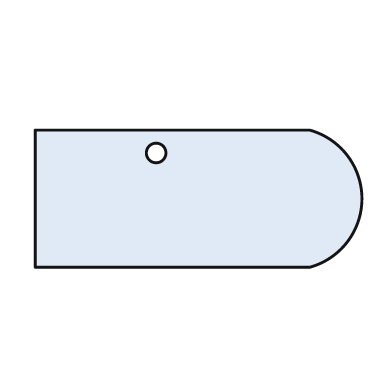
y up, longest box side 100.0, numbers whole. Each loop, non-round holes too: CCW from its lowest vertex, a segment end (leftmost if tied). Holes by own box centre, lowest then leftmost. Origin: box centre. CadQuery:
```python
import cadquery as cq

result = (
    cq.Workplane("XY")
    .moveTo(-50.0, -21.0)
    .lineTo(34.0, -21.0)
    .threePointArc((50.0, 0.0), (34.0, 21.0))
    .lineTo(-50.0, 21.0)
    .close()
    .moveTo(-13.0, 14.0)
    .circle(3.0)
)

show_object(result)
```